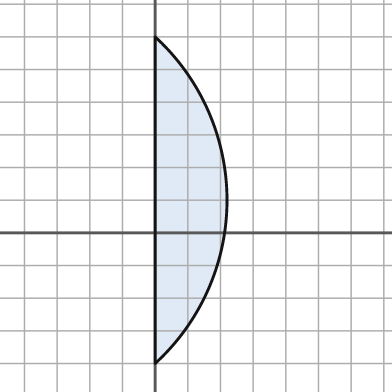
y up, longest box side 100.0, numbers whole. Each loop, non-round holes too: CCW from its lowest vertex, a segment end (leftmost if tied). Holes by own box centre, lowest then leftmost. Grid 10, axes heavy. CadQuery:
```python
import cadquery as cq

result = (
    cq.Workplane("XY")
    .moveTo(0.0, -40.0)
    .threePointArc((22.0, 10.0), (0.0, 60.0))
    .close()
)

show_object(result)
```